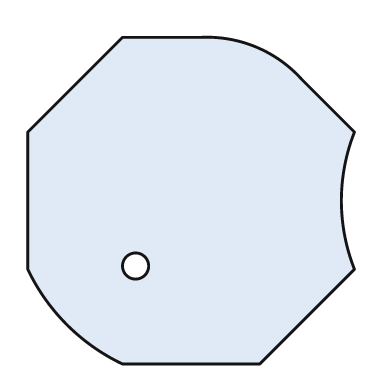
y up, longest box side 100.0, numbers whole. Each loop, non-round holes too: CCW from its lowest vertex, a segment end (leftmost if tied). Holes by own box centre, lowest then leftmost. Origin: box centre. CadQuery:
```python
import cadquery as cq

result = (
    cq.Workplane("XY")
    .moveTo(-21.0, -50.0)
    .lineTo(21.0, -50.0)
    .lineTo(50.0, -21.0)
    .threePointArc((46.0, 0.0), (50.0, 21.0))
    .lineTo(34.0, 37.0)
    .threePointArc((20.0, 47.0), (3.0, 50.0))
    .lineTo(-21.0, 50.0)
    .lineTo(-50.0, 21.0)
    .lineTo(-50.0, -21.0)
    .threePointArc((-38.0, -38.0), (-21.0, -50.0))
    .close()
    .moveTo(-17.0, -20.0)
    .circle(4.0)
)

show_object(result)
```